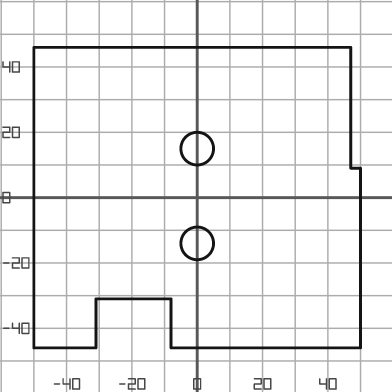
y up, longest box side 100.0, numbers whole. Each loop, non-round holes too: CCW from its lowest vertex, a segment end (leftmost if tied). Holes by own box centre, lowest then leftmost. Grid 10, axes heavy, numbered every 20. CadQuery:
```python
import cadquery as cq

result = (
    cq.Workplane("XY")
    .moveTo(-50.0, -46.0)
    .lineTo(-31.0, -46.0)
    .lineTo(-31.0, -31.0)
    .lineTo(-8.0, -31.0)
    .lineTo(-8.0, -46.0)
    .lineTo(50.0, -46.0)
    .lineTo(50.0, 9.0)
    .lineTo(47.0, 9.0)
    .lineTo(47.0, 46.0)
    .lineTo(-50.0, 46.0)
    .close()
    .moveTo(0.0, -14.0)
    .circle(5.0)
    .moveTo(0.0, 15.0)
    .circle(5.0)
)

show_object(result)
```